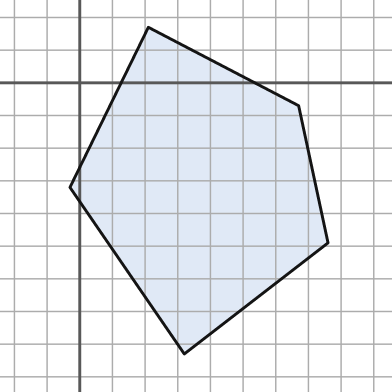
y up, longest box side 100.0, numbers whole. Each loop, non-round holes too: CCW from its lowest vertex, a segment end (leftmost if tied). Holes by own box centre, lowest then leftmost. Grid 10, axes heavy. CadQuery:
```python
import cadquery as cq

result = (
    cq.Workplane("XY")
    .moveTo(32.0, -83.0)
    .lineTo(76.0, -49.0)
    .lineTo(67.0, -7.0)
    .lineTo(21.0, 17.0)
    .lineTo(-3.0, -32.0)
    .close()
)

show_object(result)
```